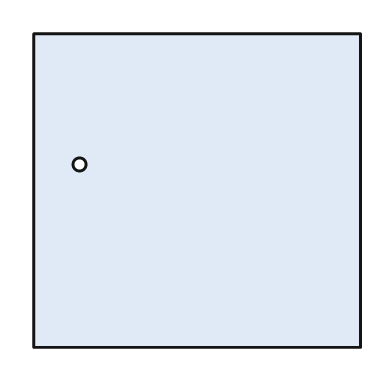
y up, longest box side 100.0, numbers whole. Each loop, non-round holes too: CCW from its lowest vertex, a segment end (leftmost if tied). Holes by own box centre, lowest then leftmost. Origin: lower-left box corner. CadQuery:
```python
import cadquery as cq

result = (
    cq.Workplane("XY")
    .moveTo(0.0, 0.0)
    .lineTo(100.0, 0.0)
    .lineTo(100.0, 96.0)
    .lineTo(0.0, 96.0)
    .close()
    .moveTo(14.0, 56.0)
    .circle(2.0)
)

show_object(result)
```